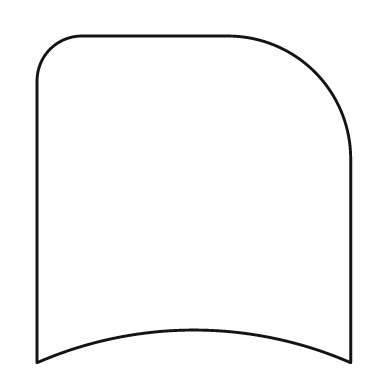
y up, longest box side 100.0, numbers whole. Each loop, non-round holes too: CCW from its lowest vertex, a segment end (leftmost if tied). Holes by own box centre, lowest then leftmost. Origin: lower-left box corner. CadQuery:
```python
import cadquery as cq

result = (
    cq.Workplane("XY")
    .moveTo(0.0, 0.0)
    .threePointArc((48.0, 10.0), (96.0, 0.0))
    .lineTo(96.0, 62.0)
    .threePointArc((85.0, 89.0), (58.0, 100.0))
    .lineTo(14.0, 100.0)
    .threePointArc((4.0, 96.0), (0.0, 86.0))
    .close()
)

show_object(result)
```